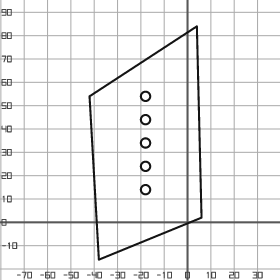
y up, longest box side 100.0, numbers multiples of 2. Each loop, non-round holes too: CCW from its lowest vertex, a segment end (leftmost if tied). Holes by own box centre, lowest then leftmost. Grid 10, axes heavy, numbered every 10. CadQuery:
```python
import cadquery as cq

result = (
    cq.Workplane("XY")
    .moveTo(-38.0, -16.0)
    .lineTo(6.0, 2.0)
    .lineTo(4.0, 84.0)
    .lineTo(-42.0, 54.0)
    .close()
    .moveTo(-18.0, 14.0)
    .circle(2.0)
    .moveTo(-18.0, 24.0)
    .circle(2.0)
    .moveTo(-18.0, 34.0)
    .circle(2.0)
    .moveTo(-18.0, 44.0)
    .circle(2.0)
    .moveTo(-18.0, 54.0)
    .circle(2.0)
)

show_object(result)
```